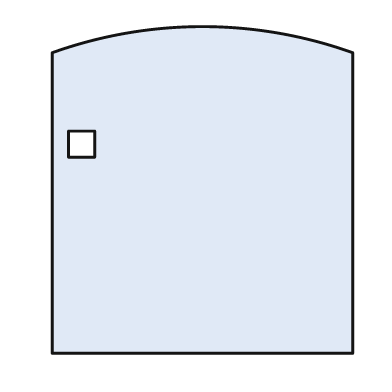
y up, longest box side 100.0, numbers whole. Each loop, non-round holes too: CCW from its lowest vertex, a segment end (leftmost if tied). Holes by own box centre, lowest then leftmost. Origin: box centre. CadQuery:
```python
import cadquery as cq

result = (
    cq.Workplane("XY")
    .moveTo(-46.0, -50.0)
    .lineTo(46.0, -50.0)
    .lineTo(46.0, 42.0)
    .threePointArc((0.0, 50.0), (-46.0, 42.0))
    .close()
    .moveTo(-41.0, 10.0)
    .lineTo(-33.0, 10.0)
    .lineTo(-33.0, 18.0)
    .lineTo(-41.0, 18.0)
    .close()
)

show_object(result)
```